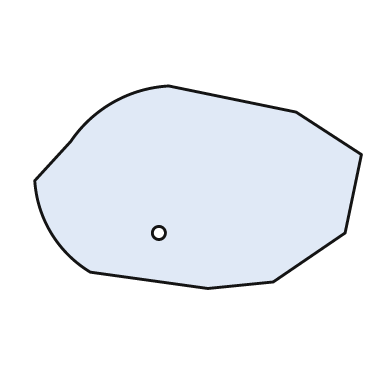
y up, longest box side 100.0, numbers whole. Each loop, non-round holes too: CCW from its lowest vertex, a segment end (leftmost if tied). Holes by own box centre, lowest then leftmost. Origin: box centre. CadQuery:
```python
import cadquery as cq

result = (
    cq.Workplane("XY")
    .moveTo(3.0, -31.0)
    .lineTo(23.0, -29.0)
    .lineTo(45.0, -14.0)
    .lineTo(50.0, 10.0)
    .lineTo(30.0, 23.0)
    .lineTo(-9.0, 31.0)
    .threePointArc((-26.0, 26.0), (-39.0, 14.0))
    .lineTo(-50.0, 2.0)
    .threePointArc((-45.0, -14.0), (-33.0, -26.0))
    .close()
    .moveTo(-12.0, -14.0)
    .circle(2.0)
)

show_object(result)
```